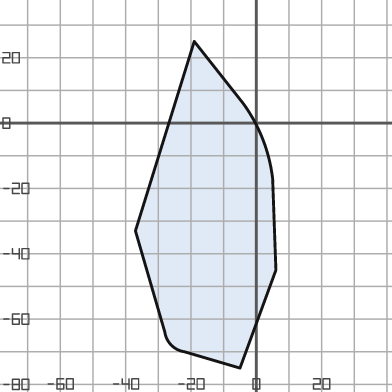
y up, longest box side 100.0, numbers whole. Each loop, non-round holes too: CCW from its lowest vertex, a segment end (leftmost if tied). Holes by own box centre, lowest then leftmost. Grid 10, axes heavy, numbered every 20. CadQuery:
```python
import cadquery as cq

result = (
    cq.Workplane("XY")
    .moveTo(-5.0, -75.0)
    .lineTo(6.0, -45.0)
    .lineTo(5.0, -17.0)
    .threePointArc((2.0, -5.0), (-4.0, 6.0))
    .lineTo(-19.0, 25.0)
    .lineTo(-37.0, -33.0)
    .lineTo(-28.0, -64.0)
    .threePointArc((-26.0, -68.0), (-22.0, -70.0))
    .close()
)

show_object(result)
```